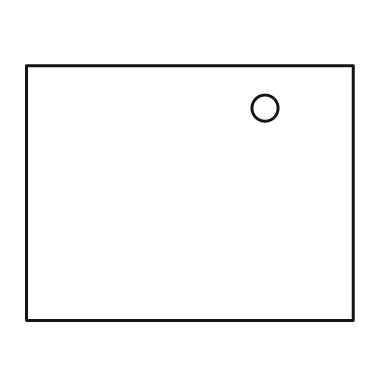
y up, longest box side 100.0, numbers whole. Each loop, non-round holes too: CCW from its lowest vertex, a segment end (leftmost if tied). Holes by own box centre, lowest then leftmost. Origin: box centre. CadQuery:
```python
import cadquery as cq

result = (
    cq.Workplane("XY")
    .moveTo(-50.0, -39.0)
    .lineTo(50.0, -39.0)
    .lineTo(50.0, 39.0)
    .lineTo(-50.0, 39.0)
    .close()
    .moveTo(23.0, 26.0)
    .circle(4.0)
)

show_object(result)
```